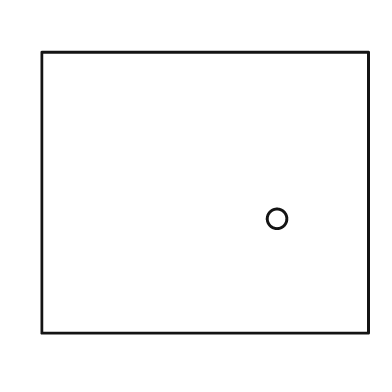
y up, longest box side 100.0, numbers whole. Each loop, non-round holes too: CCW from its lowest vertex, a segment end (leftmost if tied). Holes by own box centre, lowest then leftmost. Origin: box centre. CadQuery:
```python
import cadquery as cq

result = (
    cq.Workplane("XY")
    .moveTo(-50.0, -43.0)
    .lineTo(50.0, -43.0)
    .lineTo(50.0, 43.0)
    .lineTo(-50.0, 43.0)
    .close()
    .moveTo(22.0, -8.0)
    .circle(3.0)
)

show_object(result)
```